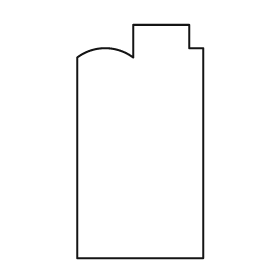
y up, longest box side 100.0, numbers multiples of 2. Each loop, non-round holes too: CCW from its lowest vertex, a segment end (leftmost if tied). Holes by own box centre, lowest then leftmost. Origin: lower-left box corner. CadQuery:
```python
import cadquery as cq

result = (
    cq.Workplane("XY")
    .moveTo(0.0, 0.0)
    .lineTo(54.0, 0.0)
    .lineTo(54.0, 90.0)
    .lineTo(48.0, 90.0)
    .lineTo(48.0, 100.0)
    .lineTo(24.0, 100.0)
    .lineTo(24.0, 86.0)
    .threePointArc((12.0, 90.0), (0.0, 86.0))
    .close()
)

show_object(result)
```